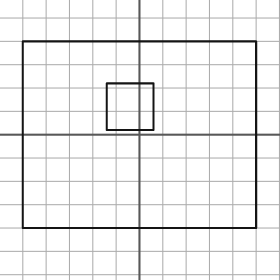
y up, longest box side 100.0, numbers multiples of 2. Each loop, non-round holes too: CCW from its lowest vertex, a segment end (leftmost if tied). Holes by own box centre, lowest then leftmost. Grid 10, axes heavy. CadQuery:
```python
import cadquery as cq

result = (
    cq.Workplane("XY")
    .moveTo(-50.0, -40.0)
    .lineTo(50.0, -40.0)
    .lineTo(50.0, 40.0)
    .lineTo(-50.0, 40.0)
    .close()
    .moveTo(-14.0, 2.0)
    .lineTo(6.0, 2.0)
    .lineTo(6.0, 22.0)
    .lineTo(-14.0, 22.0)
    .close()
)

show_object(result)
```